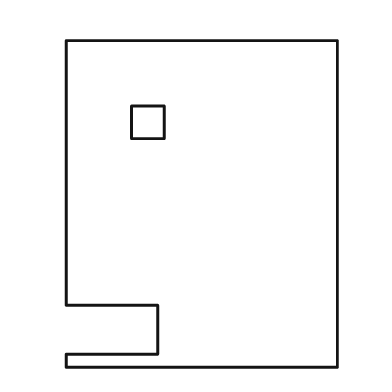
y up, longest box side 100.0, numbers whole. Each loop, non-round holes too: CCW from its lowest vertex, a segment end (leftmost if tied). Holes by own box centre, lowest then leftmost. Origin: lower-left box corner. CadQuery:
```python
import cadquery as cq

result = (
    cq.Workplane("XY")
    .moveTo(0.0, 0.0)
    .lineTo(83.0, 0.0)
    .lineTo(83.0, 100.0)
    .lineTo(0.0, 100.0)
    .lineTo(0.0, 19.0)
    .lineTo(28.0, 19.0)
    .lineTo(28.0, 4.0)
    .lineTo(0.0, 4.0)
    .close()
    .moveTo(20.0, 70.0)
    .lineTo(30.0, 70.0)
    .lineTo(30.0, 80.0)
    .lineTo(20.0, 80.0)
    .close()
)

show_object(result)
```